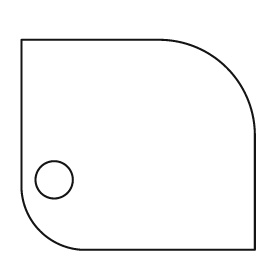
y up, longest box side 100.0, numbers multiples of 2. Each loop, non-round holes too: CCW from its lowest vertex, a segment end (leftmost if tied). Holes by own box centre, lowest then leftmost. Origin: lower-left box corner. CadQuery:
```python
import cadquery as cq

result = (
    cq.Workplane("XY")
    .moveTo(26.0, 0.0)
    .lineTo(100.0, 0.0)
    .lineTo(100.0, 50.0)
    .threePointArc((88.0, 78.0), (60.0, 90.0))
    .lineTo(0.0, 90.0)
    .lineTo(0.0, 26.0)
    .threePointArc((8.0, 8.0), (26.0, 0.0))
    .close()
    .moveTo(14.0, 30.0)
    .circle(8.0)
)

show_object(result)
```